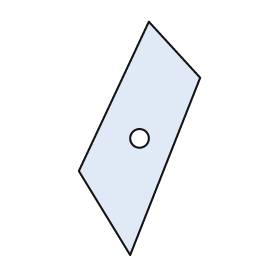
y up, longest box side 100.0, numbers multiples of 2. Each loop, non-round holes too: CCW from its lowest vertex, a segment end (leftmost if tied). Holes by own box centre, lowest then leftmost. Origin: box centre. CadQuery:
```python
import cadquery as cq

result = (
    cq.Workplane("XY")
    .moveTo(-4.0, -50.0)
    .lineTo(26.0, 26.0)
    .lineTo(4.0, 50.0)
    .lineTo(-26.0, -14.0)
    .close()
    .moveTo(0.0, 0.0)
    .circle(4.0)
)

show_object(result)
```